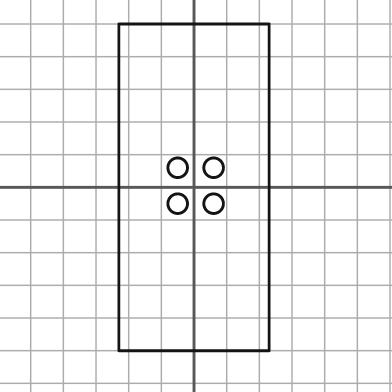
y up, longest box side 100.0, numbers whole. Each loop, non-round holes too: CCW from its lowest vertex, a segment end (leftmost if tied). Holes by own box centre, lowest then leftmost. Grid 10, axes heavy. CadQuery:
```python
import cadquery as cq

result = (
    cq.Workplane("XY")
    .moveTo(-23.0, -50.0)
    .lineTo(23.0, -50.0)
    .lineTo(23.0, 50.0)
    .lineTo(-23.0, 50.0)
    .close()
    .moveTo(-5.0, -5.0)
    .circle(3.0)
    .moveTo(6.0, -5.0)
    .circle(3.0)
    .moveTo(-5.0, 6.0)
    .circle(3.0)
    .moveTo(6.0, 6.0)
    .circle(3.0)
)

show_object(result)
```